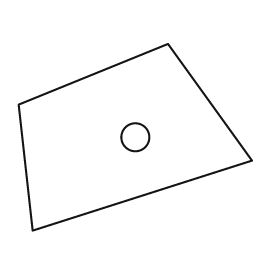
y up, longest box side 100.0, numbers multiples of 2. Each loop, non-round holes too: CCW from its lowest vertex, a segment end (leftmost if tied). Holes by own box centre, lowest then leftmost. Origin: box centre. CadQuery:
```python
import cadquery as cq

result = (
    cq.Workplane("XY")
    .moveTo(-44.0, -40.0)
    .lineTo(50.0, -10.0)
    .lineTo(14.0, 40.0)
    .lineTo(-50.0, 14.0)
    .close()
    .moveTo(0.0, 0.0)
    .circle(6.0)
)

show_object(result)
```